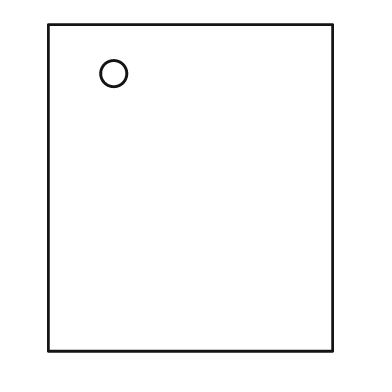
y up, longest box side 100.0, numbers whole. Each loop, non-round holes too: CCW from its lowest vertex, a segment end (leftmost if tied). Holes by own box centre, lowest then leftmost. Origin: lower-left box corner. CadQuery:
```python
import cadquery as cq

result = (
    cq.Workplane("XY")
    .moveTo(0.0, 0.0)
    .lineTo(87.0, 0.0)
    .lineTo(87.0, 100.0)
    .lineTo(0.0, 100.0)
    .close()
    .moveTo(20.0, 85.0)
    .circle(4.0)
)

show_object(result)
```